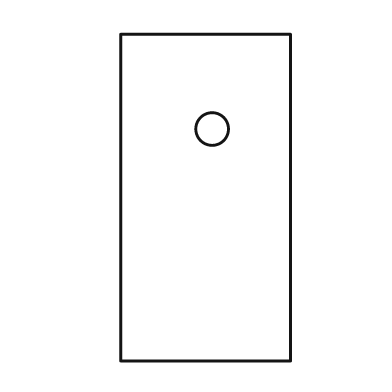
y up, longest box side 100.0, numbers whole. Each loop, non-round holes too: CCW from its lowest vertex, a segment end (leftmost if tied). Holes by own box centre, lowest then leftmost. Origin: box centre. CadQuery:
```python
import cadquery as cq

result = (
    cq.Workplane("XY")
    .moveTo(-26.0, -50.0)
    .lineTo(26.0, -50.0)
    .lineTo(26.0, 50.0)
    .lineTo(-26.0, 50.0)
    .close()
    .moveTo(2.0, 21.0)
    .circle(5.0)
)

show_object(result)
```